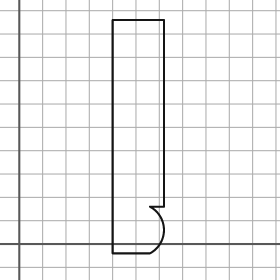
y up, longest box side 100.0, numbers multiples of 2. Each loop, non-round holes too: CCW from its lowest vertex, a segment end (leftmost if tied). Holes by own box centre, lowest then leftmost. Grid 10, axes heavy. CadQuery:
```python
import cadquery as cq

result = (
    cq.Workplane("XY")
    .moveTo(40.0, -4.0)
    .lineTo(56.0, -4.0)
    .threePointArc((62.0, 6.0), (56.0, 16.0))
    .lineTo(62.0, 16.0)
    .lineTo(62.0, 96.0)
    .lineTo(40.0, 96.0)
    .close()
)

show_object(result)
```